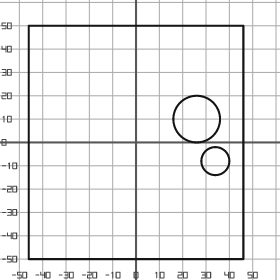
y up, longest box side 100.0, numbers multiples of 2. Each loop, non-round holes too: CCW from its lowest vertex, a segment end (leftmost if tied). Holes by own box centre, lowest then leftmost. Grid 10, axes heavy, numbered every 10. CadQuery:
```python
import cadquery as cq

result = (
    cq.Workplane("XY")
    .moveTo(-46.0, -50.0)
    .lineTo(46.0, -50.0)
    .lineTo(46.0, 50.0)
    .lineTo(-46.0, 50.0)
    .close()
    .moveTo(34.0, -8.0)
    .circle(6.0)
    .moveTo(26.0, 10.0)
    .circle(10.0)
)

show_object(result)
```